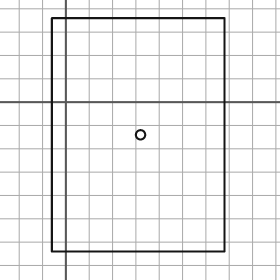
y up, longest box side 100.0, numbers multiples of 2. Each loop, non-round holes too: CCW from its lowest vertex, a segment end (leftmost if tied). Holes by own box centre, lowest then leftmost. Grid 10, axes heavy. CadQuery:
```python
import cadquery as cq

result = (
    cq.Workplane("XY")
    .moveTo(-6.0, -64.0)
    .lineTo(68.0, -64.0)
    .lineTo(68.0, 36.0)
    .lineTo(-6.0, 36.0)
    .close()
    .moveTo(32.0, -14.0)
    .circle(2.0)
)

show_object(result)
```